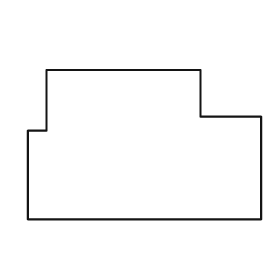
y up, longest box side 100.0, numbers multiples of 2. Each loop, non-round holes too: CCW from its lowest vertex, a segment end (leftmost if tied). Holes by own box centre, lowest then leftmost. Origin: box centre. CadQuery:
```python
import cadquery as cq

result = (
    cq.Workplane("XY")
    .moveTo(-50.0, -32.0)
    .lineTo(50.0, -32.0)
    .lineTo(50.0, 12.0)
    .lineTo(24.0, 12.0)
    .lineTo(24.0, 32.0)
    .lineTo(-42.0, 32.0)
    .lineTo(-42.0, 6.0)
    .lineTo(-50.0, 6.0)
    .close()
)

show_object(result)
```